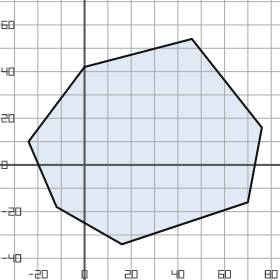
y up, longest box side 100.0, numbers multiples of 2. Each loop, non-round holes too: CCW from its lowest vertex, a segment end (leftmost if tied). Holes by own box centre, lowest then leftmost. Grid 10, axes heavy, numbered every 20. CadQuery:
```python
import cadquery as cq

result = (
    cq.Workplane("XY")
    .moveTo(16.0, -34.0)
    .lineTo(70.0, -16.0)
    .lineTo(76.0, 16.0)
    .lineTo(46.0, 54.0)
    .lineTo(0.0, 42.0)
    .lineTo(-24.0, 10.0)
    .lineTo(-12.0, -18.0)
    .close()
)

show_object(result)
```